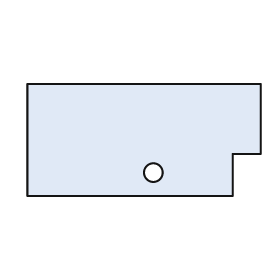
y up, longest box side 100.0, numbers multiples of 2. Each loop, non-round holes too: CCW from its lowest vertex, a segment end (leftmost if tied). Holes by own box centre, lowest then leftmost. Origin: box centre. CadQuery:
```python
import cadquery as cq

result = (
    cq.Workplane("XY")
    .moveTo(-50.0, -24.0)
    .lineTo(38.0, -24.0)
    .lineTo(38.0, -6.0)
    .lineTo(50.0, -6.0)
    .lineTo(50.0, 24.0)
    .lineTo(-50.0, 24.0)
    .close()
    .moveTo(4.0, -14.0)
    .circle(4.0)
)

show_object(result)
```